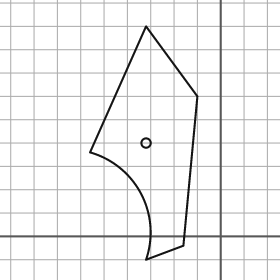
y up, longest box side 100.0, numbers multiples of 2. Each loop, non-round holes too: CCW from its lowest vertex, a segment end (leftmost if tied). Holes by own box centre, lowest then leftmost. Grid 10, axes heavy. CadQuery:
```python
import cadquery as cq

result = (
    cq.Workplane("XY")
    .moveTo(-32.0, -10.0)
    .lineTo(-16.0, -4.0)
    .lineTo(-10.0, 60.0)
    .lineTo(-32.0, 90.0)
    .lineTo(-56.0, 36.0)
    .threePointArc((-34.0, 18.0), (-32.0, -10.0))
    .close()
    .moveTo(-32.0, 40.0)
    .circle(2.0)
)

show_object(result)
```